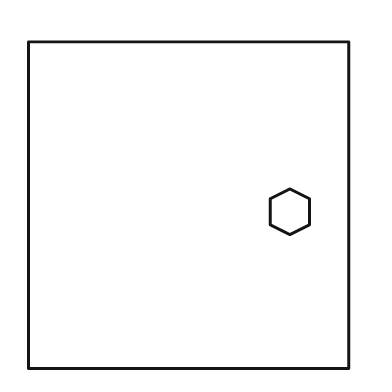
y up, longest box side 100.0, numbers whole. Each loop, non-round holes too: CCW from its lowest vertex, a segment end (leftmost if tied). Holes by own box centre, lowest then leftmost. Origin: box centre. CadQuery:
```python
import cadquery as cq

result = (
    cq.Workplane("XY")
    .moveTo(-49.0, -50.0)
    .lineTo(49.0, -50.0)
    .lineTo(49.0, 50.0)
    .lineTo(-49.0, 50.0)
    .close()
    .moveTo(31.0, -9.0)
    .lineTo(37.0, -6.0)
    .lineTo(37.0, 2.0)
    .lineTo(31.0, 5.0)
    .lineTo(25.0, 2.0)
    .lineTo(25.0, -6.0)
    .close()
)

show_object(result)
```